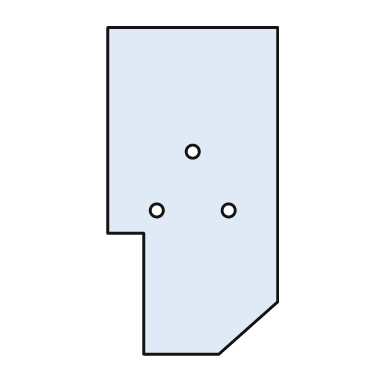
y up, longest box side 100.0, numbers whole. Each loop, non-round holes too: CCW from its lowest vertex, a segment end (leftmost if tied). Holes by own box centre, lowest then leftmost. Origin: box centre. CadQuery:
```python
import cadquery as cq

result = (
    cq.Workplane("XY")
    .moveTo(-15.0, -50.0)
    .lineTo(8.0, -50.0)
    .lineTo(26.0, -34.0)
    .lineTo(26.0, 50.0)
    .lineTo(-26.0, 50.0)
    .lineTo(-26.0, -13.0)
    .lineTo(-15.0, -13.0)
    .close()
    .moveTo(-11.0, -6.0)
    .circle(2.0)
    .moveTo(11.0, -6.0)
    .circle(2.0)
    .moveTo(0.0, 12.0)
    .circle(2.0)
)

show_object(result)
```